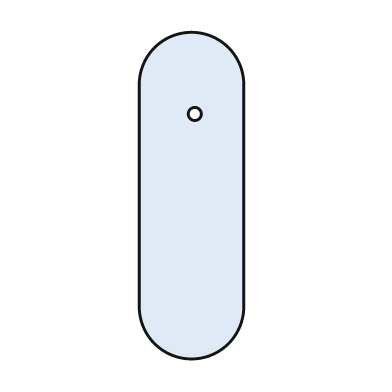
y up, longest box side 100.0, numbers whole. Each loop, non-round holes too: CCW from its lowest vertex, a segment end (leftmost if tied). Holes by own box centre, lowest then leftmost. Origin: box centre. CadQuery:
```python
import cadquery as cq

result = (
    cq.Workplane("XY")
    .moveTo(-16.0, -34.0)
    .threePointArc((0.0, -50.0), (16.0, -34.0))
    .lineTo(16.0, 34.0)
    .threePointArc((0.0, 50.0), (-16.0, 34.0))
    .close()
    .moveTo(1.0, 25.0)
    .circle(2.0)
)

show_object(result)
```